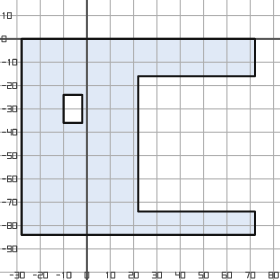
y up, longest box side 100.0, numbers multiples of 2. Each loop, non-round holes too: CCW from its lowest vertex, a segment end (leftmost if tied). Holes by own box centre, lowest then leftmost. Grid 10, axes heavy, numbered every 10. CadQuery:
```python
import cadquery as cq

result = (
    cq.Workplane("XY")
    .moveTo(-28.0, -84.0)
    .lineTo(72.0, -84.0)
    .lineTo(72.0, -74.0)
    .lineTo(22.0, -74.0)
    .lineTo(22.0, -16.0)
    .lineTo(72.0, -16.0)
    .lineTo(72.0, 0.0)
    .lineTo(-28.0, 0.0)
    .close()
    .moveTo(-10.0, -36.0)
    .lineTo(-2.0, -36.0)
    .lineTo(-2.0, -24.0)
    .lineTo(-10.0, -24.0)
    .close()
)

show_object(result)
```